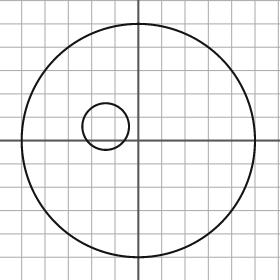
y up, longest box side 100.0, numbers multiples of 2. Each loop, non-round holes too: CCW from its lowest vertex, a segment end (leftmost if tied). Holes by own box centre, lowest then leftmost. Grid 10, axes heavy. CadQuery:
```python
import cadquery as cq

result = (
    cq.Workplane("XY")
    .moveTo(0.0, 0.0)
    .circle(50.0)
    .moveTo(-14.0, 6.0)
    .circle(10.0)
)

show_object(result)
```